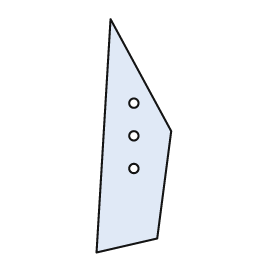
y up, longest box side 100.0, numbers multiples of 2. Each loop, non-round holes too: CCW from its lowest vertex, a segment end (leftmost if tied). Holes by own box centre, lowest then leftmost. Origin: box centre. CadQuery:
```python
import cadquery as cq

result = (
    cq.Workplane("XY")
    .moveTo(-16.0, -50.0)
    .lineTo(10.0, -44.0)
    .lineTo(16.0, 2.0)
    .lineTo(-10.0, 50.0)
    .close()
    .moveTo(0.0, -14.0)
    .circle(2.0)
    .moveTo(0.0, 0.0)
    .circle(2.0)
    .moveTo(0.0, 14.0)
    .circle(2.0)
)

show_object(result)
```